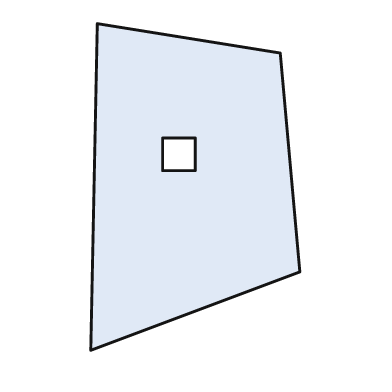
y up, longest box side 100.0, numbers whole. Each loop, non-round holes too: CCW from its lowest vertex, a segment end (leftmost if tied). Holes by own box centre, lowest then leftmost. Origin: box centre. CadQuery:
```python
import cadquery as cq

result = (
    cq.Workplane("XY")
    .moveTo(-32.0, -50.0)
    .lineTo(32.0, -26.0)
    .lineTo(26.0, 41.0)
    .lineTo(-30.0, 50.0)
    .close()
    .moveTo(-10.0, 5.0)
    .lineTo(0.0, 5.0)
    .lineTo(0.0, 15.0)
    .lineTo(-10.0, 15.0)
    .close()
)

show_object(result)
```